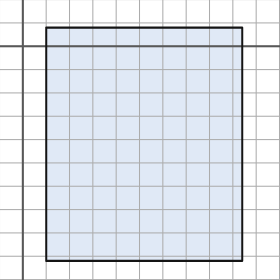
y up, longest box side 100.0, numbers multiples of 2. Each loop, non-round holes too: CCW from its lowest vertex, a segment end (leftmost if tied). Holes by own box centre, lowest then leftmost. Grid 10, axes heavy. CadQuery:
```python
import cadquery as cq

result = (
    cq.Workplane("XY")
    .moveTo(10.0, -92.0)
    .lineTo(94.0, -92.0)
    .lineTo(94.0, 8.0)
    .lineTo(10.0, 8.0)
    .close()
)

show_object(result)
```